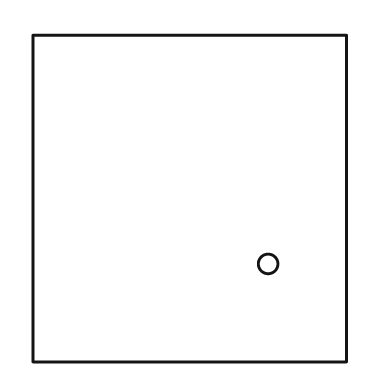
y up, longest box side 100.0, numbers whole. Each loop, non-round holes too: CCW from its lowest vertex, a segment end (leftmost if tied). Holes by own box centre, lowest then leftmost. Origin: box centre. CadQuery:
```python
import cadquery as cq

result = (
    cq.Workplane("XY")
    .moveTo(-48.0, -50.0)
    .lineTo(48.0, -50.0)
    .lineTo(48.0, 50.0)
    .lineTo(-48.0, 50.0)
    .close()
    .moveTo(24.0, -20.0)
    .circle(3.0)
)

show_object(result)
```